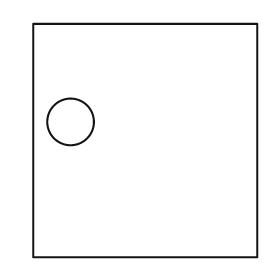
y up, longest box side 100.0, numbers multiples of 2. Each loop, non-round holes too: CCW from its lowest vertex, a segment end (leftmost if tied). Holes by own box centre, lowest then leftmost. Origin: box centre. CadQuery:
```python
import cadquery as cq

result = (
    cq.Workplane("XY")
    .moveTo(-48.0, -50.0)
    .lineTo(48.0, -50.0)
    .lineTo(48.0, 50.0)
    .lineTo(-48.0, 50.0)
    .close()
    .moveTo(-32.0, 8.0)
    .circle(10.0)
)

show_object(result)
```